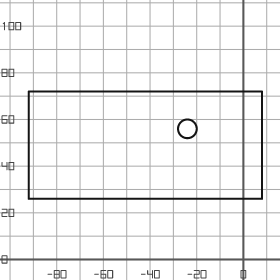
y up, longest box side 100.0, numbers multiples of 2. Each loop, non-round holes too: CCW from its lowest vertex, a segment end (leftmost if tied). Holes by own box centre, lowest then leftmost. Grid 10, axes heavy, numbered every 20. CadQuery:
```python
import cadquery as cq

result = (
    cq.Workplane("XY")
    .moveTo(-92.0, 26.0)
    .lineTo(8.0, 26.0)
    .lineTo(8.0, 72.0)
    .lineTo(-92.0, 72.0)
    .close()
    .moveTo(-24.0, 56.0)
    .circle(4.0)
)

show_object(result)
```